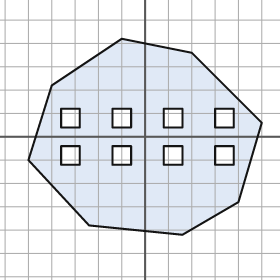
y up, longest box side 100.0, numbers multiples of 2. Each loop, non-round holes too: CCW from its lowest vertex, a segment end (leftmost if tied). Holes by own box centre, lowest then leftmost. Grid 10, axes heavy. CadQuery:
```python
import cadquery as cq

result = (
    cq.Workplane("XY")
    .moveTo(16.0, -42.0)
    .lineTo(40.0, -28.0)
    .lineTo(50.0, 6.0)
    .lineTo(20.0, 36.0)
    .lineTo(-10.0, 42.0)
    .lineTo(-40.0, 22.0)
    .lineTo(-50.0, -10.0)
    .lineTo(-24.0, -38.0)
    .close()
    .moveTo(-36.0, -12.0)
    .lineTo(-28.0, -12.0)
    .lineTo(-28.0, -4.0)
    .lineTo(-36.0, -4.0)
    .close()
    .moveTo(-14.0, -12.0)
    .lineTo(-6.0, -12.0)
    .lineTo(-6.0, -4.0)
    .lineTo(-14.0, -4.0)
    .close()
    .moveTo(8.0, -12.0)
    .lineTo(16.0, -12.0)
    .lineTo(16.0, -4.0)
    .lineTo(8.0, -4.0)
    .close()
    .moveTo(30.0, -12.0)
    .lineTo(38.0, -12.0)
    .lineTo(38.0, -4.0)
    .lineTo(30.0, -4.0)
    .close()
    .moveTo(-36.0, 4.0)
    .lineTo(-28.0, 4.0)
    .lineTo(-28.0, 12.0)
    .lineTo(-36.0, 12.0)
    .close()
    .moveTo(-14.0, 4.0)
    .lineTo(-6.0, 4.0)
    .lineTo(-6.0, 12.0)
    .lineTo(-14.0, 12.0)
    .close()
    .moveTo(8.0, 4.0)
    .lineTo(16.0, 4.0)
    .lineTo(16.0, 12.0)
    .lineTo(8.0, 12.0)
    .close()
    .moveTo(30.0, 4.0)
    .lineTo(38.0, 4.0)
    .lineTo(38.0, 12.0)
    .lineTo(30.0, 12.0)
    .close()
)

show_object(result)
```